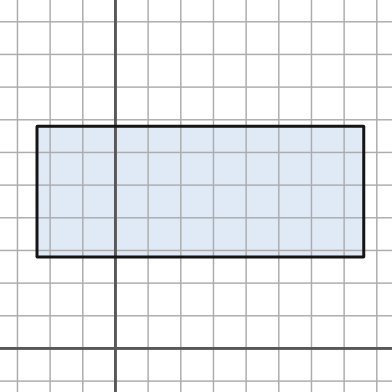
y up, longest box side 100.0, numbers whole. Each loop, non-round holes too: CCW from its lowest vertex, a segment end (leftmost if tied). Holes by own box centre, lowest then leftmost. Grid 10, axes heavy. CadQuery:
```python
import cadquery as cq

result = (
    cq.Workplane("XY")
    .moveTo(-24.0, 28.0)
    .lineTo(76.0, 28.0)
    .lineTo(76.0, 68.0)
    .lineTo(-24.0, 68.0)
    .close()
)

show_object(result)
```